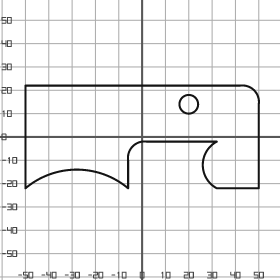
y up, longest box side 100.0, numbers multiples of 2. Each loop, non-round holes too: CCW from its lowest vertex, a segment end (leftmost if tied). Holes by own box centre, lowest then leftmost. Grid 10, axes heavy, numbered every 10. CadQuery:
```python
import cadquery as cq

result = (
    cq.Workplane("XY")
    .moveTo(-50.0, -22.0)
    .threePointArc((-28.0, -14.0), (-6.0, -22.0))
    .lineTo(-6.0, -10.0)
    .threePointArc((-4.0, -4.0), (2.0, -2.0))
    .lineTo(32.0, -2.0)
    .threePointArc((26.0, -12.0), (32.0, -22.0))
    .lineTo(50.0, -22.0)
    .lineTo(50.0, 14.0)
    .threePointArc((48.0, 20.0), (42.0, 22.0))
    .lineTo(-50.0, 22.0)
    .close()
    .moveTo(20.0, 14.0)
    .circle(4.0)
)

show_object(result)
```